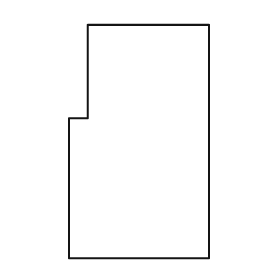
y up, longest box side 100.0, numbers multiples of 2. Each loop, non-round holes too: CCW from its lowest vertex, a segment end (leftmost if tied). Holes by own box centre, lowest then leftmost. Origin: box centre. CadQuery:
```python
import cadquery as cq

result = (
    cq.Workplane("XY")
    .moveTo(-30.0, -50.0)
    .lineTo(30.0, -50.0)
    .lineTo(30.0, 50.0)
    .lineTo(-22.0, 50.0)
    .lineTo(-22.0, 10.0)
    .lineTo(-30.0, 10.0)
    .close()
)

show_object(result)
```